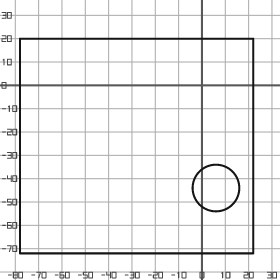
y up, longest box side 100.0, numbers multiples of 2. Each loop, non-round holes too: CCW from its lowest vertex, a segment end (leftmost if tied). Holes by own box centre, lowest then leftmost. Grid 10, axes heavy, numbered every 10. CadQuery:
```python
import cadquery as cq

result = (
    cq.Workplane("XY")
    .moveTo(-78.0, -72.0)
    .lineTo(22.0, -72.0)
    .lineTo(22.0, 20.0)
    .lineTo(-78.0, 20.0)
    .close()
    .moveTo(6.0, -44.0)
    .circle(10.0)
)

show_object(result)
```